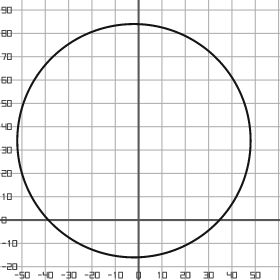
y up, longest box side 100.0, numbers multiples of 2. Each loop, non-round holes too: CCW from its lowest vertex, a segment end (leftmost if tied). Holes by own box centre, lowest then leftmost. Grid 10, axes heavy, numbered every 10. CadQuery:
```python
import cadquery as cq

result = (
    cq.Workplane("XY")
    .moveTo(-2.0, 34.0)
    .circle(50.0)
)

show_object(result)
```